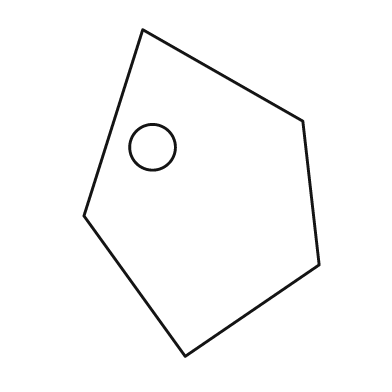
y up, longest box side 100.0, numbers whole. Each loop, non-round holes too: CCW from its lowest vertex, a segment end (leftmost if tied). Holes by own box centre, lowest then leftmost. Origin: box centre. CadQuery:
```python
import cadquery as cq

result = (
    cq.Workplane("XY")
    .moveTo(-5.0, -50.0)
    .lineTo(36.0, -22.0)
    .lineTo(31.0, 22.0)
    .lineTo(-18.0, 50.0)
    .lineTo(-36.0, -7.0)
    .close()
    .moveTo(-15.0, 14.0)
    .circle(7.0)
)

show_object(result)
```